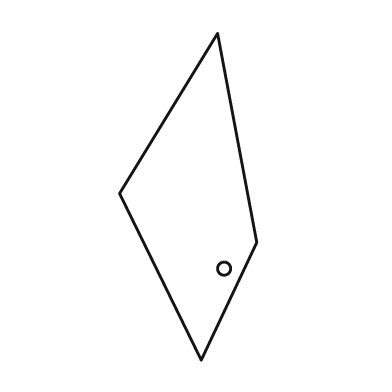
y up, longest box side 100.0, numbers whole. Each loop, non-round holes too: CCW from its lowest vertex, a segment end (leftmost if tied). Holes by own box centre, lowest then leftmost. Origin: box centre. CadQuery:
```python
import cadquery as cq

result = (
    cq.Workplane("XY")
    .moveTo(4.0, -50.0)
    .lineTo(21.0, -14.0)
    .lineTo(9.0, 50.0)
    .lineTo(-21.0, 1.0)
    .close()
    .moveTo(11.0, -22.0)
    .circle(2.0)
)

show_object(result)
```